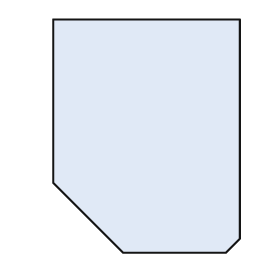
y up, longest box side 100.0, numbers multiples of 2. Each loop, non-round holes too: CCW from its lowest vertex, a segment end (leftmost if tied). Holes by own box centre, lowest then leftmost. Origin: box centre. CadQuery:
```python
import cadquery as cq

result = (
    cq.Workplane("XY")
    .moveTo(-10.0, -50.0)
    .lineTo(34.0, -50.0)
    .lineTo(40.0, -44.0)
    .lineTo(40.0, 50.0)
    .lineTo(-40.0, 50.0)
    .lineTo(-40.0, -20.0)
    .close()
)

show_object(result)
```